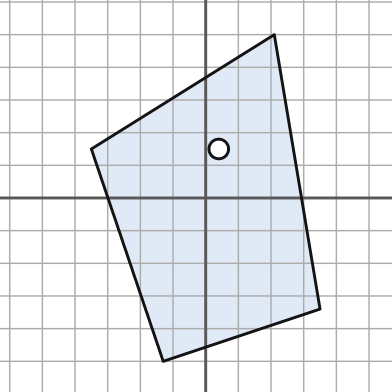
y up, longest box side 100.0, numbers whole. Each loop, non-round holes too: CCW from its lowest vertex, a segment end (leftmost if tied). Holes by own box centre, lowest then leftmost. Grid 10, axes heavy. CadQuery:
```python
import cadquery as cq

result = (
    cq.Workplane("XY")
    .moveTo(-13.0, -50.0)
    .lineTo(35.0, -34.0)
    .lineTo(21.0, 50.0)
    .lineTo(-35.0, 15.0)
    .close()
    .moveTo(4.0, 15.0)
    .circle(3.0)
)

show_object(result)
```